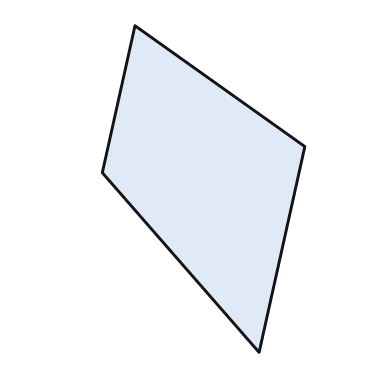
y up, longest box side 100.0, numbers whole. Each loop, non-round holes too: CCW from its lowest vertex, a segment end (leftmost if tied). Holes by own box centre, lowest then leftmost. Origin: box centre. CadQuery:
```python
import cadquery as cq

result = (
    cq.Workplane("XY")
    .moveTo(17.0, -50.0)
    .lineTo(31.0, 13.0)
    .lineTo(-21.0, 50.0)
    .lineTo(-31.0, 5.0)
    .close()
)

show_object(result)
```